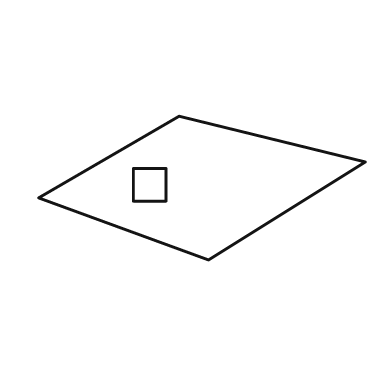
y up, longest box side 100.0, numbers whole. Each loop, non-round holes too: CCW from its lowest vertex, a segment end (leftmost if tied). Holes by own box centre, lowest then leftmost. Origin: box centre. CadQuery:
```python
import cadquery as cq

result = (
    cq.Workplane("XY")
    .moveTo(2.0, -22.0)
    .lineTo(50.0, 8.0)
    .lineTo(-7.0, 22.0)
    .lineTo(-50.0, -3.0)
    .close()
    .moveTo(-21.0, -4.0)
    .lineTo(-11.0, -4.0)
    .lineTo(-11.0, 6.0)
    .lineTo(-21.0, 6.0)
    .close()
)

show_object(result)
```